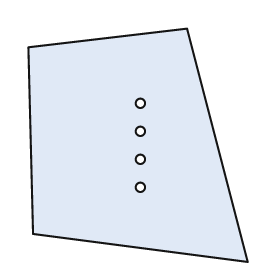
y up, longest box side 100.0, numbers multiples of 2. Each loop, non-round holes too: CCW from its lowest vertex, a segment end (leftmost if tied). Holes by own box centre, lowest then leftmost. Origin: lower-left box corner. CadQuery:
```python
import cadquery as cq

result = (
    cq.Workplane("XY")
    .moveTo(94.0, 0.0)
    .lineTo(68.0, 100.0)
    .lineTo(0.0, 92.0)
    .lineTo(2.0, 12.0)
    .close()
    .moveTo(48.0, 32.0)
    .circle(2.0)
    .moveTo(48.0, 44.0)
    .circle(2.0)
    .moveTo(48.0, 56.0)
    .circle(2.0)
    .moveTo(48.0, 68.0)
    .circle(2.0)
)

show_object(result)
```